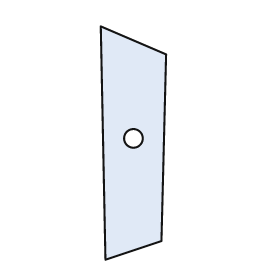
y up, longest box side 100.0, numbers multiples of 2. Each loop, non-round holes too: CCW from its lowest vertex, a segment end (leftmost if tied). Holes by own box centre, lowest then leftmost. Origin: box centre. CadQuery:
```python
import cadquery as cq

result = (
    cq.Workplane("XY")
    .moveTo(-12.0, -50.0)
    .lineTo(12.0, -42.0)
    .lineTo(14.0, 38.0)
    .lineTo(-14.0, 50.0)
    .close()
    .moveTo(0.0, 2.0)
    .circle(4.0)
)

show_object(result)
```